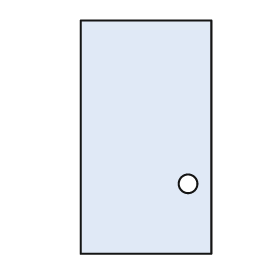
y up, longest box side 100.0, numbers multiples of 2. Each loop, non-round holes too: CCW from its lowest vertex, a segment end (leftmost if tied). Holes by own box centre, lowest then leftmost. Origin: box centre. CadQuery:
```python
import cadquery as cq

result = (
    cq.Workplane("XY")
    .moveTo(-28.0, -50.0)
    .lineTo(28.0, -50.0)
    .lineTo(28.0, 50.0)
    .lineTo(-28.0, 50.0)
    .close()
    .moveTo(18.0, -20.0)
    .circle(4.0)
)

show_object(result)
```